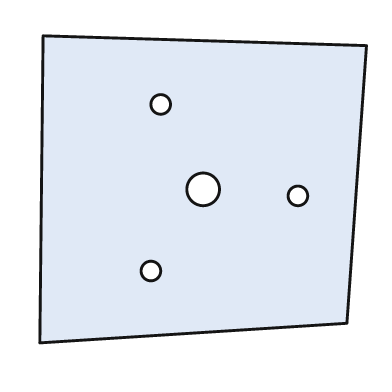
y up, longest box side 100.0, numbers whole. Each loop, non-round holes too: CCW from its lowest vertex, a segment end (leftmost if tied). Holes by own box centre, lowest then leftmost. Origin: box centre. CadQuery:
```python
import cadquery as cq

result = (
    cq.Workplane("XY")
    .moveTo(-50.0, -47.0)
    .lineTo(44.0, -41.0)
    .lineTo(50.0, 44.0)
    .lineTo(-49.0, 47.0)
    .close()
    .moveTo(-16.0, -25.0)
    .circle(3.0)
    .moveTo(29.0, -2.0)
    .circle(3.0)
    .moveTo(0.0, 0.0)
    .circle(5.0)
    .moveTo(-13.0, 26.0)
    .circle(3.0)
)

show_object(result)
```